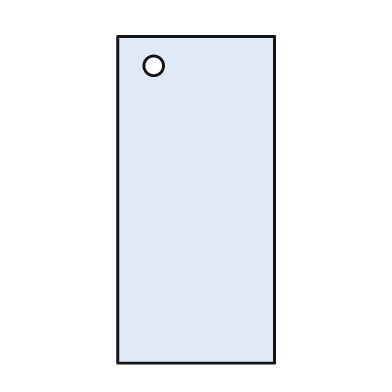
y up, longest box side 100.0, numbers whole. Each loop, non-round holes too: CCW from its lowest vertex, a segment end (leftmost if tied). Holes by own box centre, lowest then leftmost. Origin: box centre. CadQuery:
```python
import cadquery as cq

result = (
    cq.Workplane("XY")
    .moveTo(-24.0, -50.0)
    .lineTo(24.0, -50.0)
    .lineTo(24.0, 50.0)
    .lineTo(-24.0, 50.0)
    .close()
    .moveTo(-13.0, 41.0)
    .circle(3.0)
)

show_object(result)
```